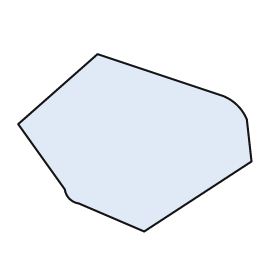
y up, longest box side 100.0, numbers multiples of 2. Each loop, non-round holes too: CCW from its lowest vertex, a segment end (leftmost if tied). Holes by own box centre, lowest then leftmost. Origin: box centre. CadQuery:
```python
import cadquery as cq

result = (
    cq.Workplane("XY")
    .moveTo(4.0, -38.0)
    .lineTo(50.0, -8.0)
    .lineTo(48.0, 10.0)
    .threePointArc((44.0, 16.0), (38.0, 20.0))
    .lineTo(-16.0, 38.0)
    .lineTo(-50.0, 8.0)
    .lineTo(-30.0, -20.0)
    .threePointArc((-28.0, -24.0), (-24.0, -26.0))
    .close()
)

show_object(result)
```